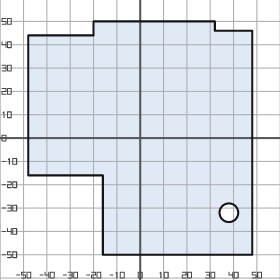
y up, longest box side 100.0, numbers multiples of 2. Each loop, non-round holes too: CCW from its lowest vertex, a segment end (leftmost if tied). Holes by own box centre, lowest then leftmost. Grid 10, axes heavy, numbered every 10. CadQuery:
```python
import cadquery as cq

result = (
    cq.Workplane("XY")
    .moveTo(-16.0, -50.0)
    .lineTo(48.0, -50.0)
    .lineTo(48.0, 46.0)
    .lineTo(32.0, 46.0)
    .lineTo(32.0, 50.0)
    .lineTo(-20.0, 50.0)
    .lineTo(-20.0, 44.0)
    .lineTo(-48.0, 44.0)
    .lineTo(-48.0, -16.0)
    .lineTo(-16.0, -16.0)
    .close()
    .moveTo(38.0, -32.0)
    .circle(4.0)
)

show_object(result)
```